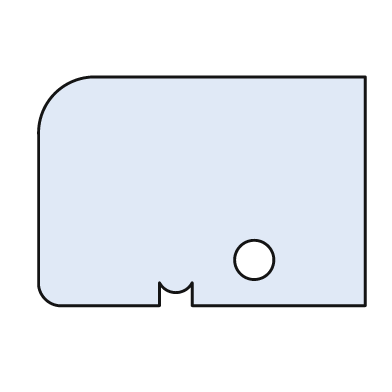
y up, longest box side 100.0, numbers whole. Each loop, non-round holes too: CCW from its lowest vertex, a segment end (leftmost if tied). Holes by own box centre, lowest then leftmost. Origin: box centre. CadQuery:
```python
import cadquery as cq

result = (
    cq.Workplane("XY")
    .moveTo(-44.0, -35.0)
    .lineTo(-13.0, -35.0)
    .lineTo(-13.0, -28.0)
    .threePointArc((-8.0, -31.0), (-3.0, -28.0))
    .lineTo(-3.0, -35.0)
    .lineTo(50.0, -35.0)
    .lineTo(50.0, 35.0)
    .lineTo(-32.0, 35.0)
    .threePointArc((-45.0, 30.0), (-50.0, 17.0))
    .lineTo(-50.0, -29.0)
    .threePointArc((-48.0, -33.0), (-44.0, -35.0))
    .close()
    .moveTo(16.0, -21.0)
    .circle(6.0)
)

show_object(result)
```